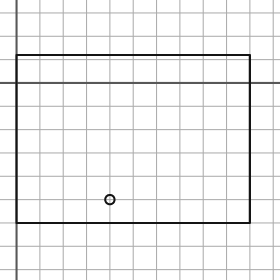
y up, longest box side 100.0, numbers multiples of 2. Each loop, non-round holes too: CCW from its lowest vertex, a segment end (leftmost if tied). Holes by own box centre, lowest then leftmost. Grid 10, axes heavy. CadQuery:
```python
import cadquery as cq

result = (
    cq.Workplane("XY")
    .moveTo(0.0, -60.0)
    .lineTo(100.0, -60.0)
    .lineTo(100.0, 12.0)
    .lineTo(0.0, 12.0)
    .close()
    .moveTo(40.0, -50.0)
    .circle(2.0)
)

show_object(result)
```